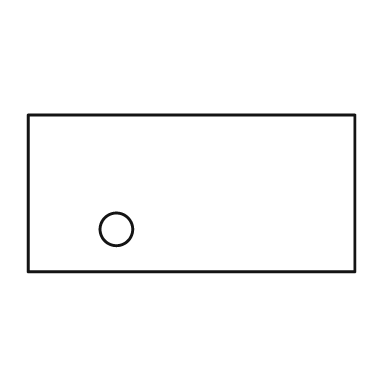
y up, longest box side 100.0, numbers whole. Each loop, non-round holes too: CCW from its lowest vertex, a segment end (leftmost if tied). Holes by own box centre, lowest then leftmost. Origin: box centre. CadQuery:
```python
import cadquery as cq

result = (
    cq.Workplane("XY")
    .moveTo(-50.0, -24.0)
    .lineTo(50.0, -24.0)
    .lineTo(50.0, 24.0)
    .lineTo(-50.0, 24.0)
    .close()
    .moveTo(-23.0, -11.0)
    .circle(5.0)
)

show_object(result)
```